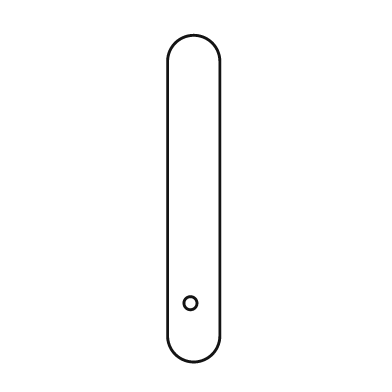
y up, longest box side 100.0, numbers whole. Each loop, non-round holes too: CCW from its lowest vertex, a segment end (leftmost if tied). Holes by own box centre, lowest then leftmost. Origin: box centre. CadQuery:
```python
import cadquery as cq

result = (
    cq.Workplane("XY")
    .moveTo(-8.0, -42.0)
    .threePointArc((0.0, -50.0), (8.0, -42.0))
    .lineTo(8.0, 42.0)
    .threePointArc((0.0, 50.0), (-8.0, 42.0))
    .close()
    .moveTo(-1.0, -32.0)
    .circle(2.0)
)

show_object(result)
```